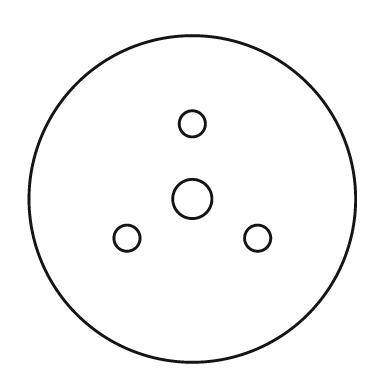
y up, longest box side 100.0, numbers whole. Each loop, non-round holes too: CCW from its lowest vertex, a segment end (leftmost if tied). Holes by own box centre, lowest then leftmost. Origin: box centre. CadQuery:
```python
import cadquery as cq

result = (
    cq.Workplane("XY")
    .moveTo(0.0, 0.0)
    .circle(50.0)
    .moveTo(-20.0, -12.0)
    .circle(4.0)
    .moveTo(20.0, -12.0)
    .circle(4.0)
    .moveTo(0.0, 0.0)
    .circle(6.0)
    .moveTo(0.0, 23.0)
    .circle(4.0)
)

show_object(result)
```